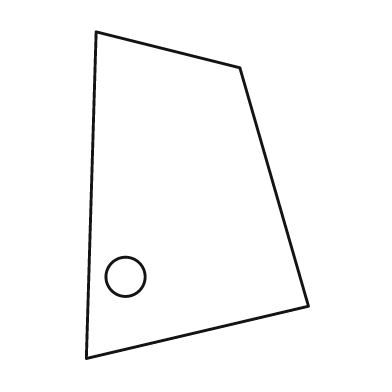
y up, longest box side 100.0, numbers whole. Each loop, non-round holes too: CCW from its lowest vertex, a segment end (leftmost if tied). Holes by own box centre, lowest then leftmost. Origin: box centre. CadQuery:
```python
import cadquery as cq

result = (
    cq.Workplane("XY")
    .moveTo(-34.0, -50.0)
    .lineTo(34.0, -34.0)
    .lineTo(13.0, 39.0)
    .lineTo(-31.0, 50.0)
    .close()
    .moveTo(-22.0, -25.0)
    .circle(6.0)
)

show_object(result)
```